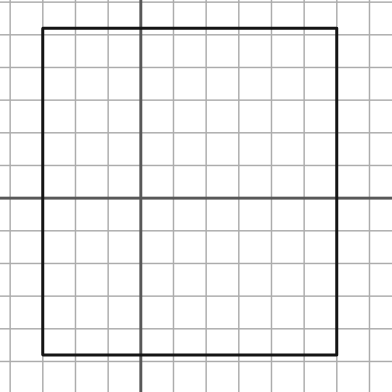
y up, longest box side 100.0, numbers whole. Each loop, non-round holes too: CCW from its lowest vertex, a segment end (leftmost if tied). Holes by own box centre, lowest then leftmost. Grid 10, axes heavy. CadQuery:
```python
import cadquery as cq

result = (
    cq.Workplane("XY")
    .moveTo(-30.0, -48.0)
    .lineTo(60.0, -48.0)
    .lineTo(60.0, 52.0)
    .lineTo(-30.0, 52.0)
    .close()
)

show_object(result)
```